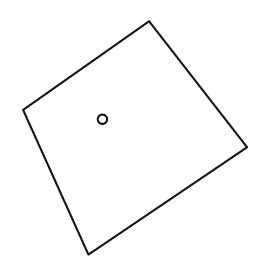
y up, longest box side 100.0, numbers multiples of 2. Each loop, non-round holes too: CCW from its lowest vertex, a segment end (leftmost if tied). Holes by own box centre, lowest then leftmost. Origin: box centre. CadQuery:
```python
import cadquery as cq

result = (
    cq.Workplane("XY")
    .moveTo(-20.0, -50.0)
    .lineTo(48.0, -4.0)
    .lineTo(6.0, 50.0)
    .lineTo(-48.0, 12.0)
    .close()
    .moveTo(-14.0, 8.0)
    .circle(2.0)
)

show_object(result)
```